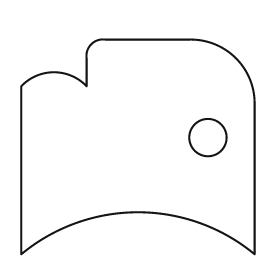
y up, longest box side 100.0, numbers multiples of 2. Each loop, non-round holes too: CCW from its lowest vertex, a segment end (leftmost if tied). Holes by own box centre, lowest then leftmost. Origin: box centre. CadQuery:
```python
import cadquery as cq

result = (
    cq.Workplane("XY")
    .moveTo(-50.0, -46.0)
    .threePointArc((0.0, -28.0), (50.0, -46.0))
    .lineTo(50.0, 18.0)
    .threePointArc((42.0, 38.0), (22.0, 46.0))
    .lineTo(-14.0, 46.0)
    .threePointArc((-20.0, 44.0), (-22.0, 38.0))
    .lineTo(-22.0, 26.0)
    .threePointArc((-36.0, 32.0), (-50.0, 26.0))
    .close()
    .moveTo(30.0, 4.0)
    .circle(8.0)
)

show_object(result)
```